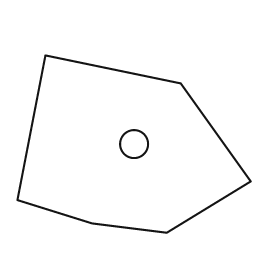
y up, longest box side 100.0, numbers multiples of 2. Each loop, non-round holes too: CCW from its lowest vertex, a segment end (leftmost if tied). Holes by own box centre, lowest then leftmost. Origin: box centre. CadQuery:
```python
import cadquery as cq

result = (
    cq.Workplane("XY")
    .moveTo(14.0, -38.0)
    .lineTo(50.0, -16.0)
    .lineTo(20.0, 26.0)
    .lineTo(-38.0, 38.0)
    .lineTo(-50.0, -24.0)
    .lineTo(-18.0, -34.0)
    .close()
    .moveTo(0.0, 0.0)
    .circle(6.0)
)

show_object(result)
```